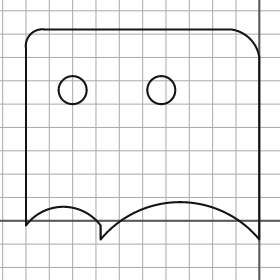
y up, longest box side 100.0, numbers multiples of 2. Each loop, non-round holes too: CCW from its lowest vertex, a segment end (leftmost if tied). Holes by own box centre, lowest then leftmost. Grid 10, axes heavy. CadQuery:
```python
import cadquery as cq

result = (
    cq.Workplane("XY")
    .moveTo(-68.0, -8.0)
    .threePointArc((-34.0, 8.0), (0.0, -8.0))
    .lineTo(0.0, 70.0)
    .threePointArc((-4.0, 78.0), (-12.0, 82.0))
    .lineTo(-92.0, 82.0)
    .threePointArc((-98.0, 80.0), (-100.0, 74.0))
    .lineTo(-100.0, -2.0)
    .threePointArc((-84.0, 6.0), (-68.0, -2.0))
    .close()
    .moveTo(-80.0, 56.0)
    .circle(6.0)
    .moveTo(-42.0, 56.0)
    .circle(6.0)
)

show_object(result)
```